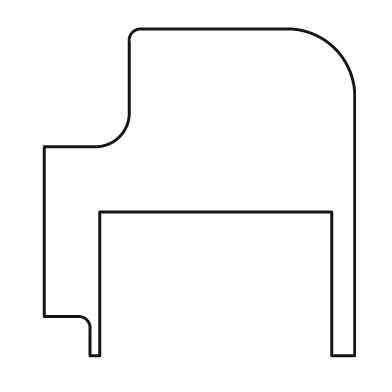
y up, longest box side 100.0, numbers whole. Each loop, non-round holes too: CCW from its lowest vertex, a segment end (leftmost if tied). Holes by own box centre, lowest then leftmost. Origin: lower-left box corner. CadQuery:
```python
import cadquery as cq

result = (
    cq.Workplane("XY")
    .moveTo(14.0, 0.0)
    .lineTo(17.0, 0.0)
    .lineTo(17.0, 44.0)
    .lineTo(88.0, 44.0)
    .lineTo(88.0, 0.0)
    .lineTo(95.0, 0.0)
    .lineTo(95.0, 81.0)
    .threePointArc((89.0, 94.0), (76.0, 100.0))
    .lineTo(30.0, 100.0)
    .threePointArc((27.0, 99.0), (26.0, 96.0))
    .lineTo(26.0, 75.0)
    .threePointArc((23.0, 67.0), (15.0, 64.0))
    .lineTo(0.0, 64.0)
    .lineTo(0.0, 12.0)
    .lineTo(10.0, 12.0)
    .threePointArc((13.0, 11.0), (14.0, 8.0))
    .close()
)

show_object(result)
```